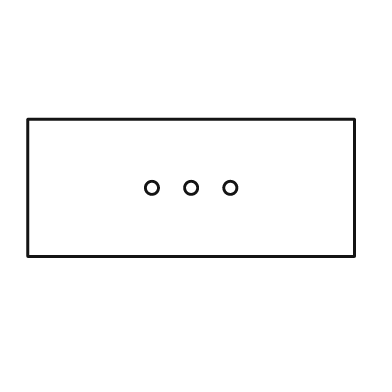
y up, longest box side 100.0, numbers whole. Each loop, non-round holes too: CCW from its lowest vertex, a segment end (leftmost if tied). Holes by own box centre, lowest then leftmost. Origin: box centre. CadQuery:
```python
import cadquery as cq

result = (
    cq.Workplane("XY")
    .moveTo(-50.0, -21.0)
    .lineTo(50.0, -21.0)
    .lineTo(50.0, 21.0)
    .lineTo(-50.0, 21.0)
    .close()
    .moveTo(-12.0, 0.0)
    .circle(2.0)
    .moveTo(0.0, 0.0)
    .circle(2.0)
    .moveTo(12.0, 0.0)
    .circle(2.0)
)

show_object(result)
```